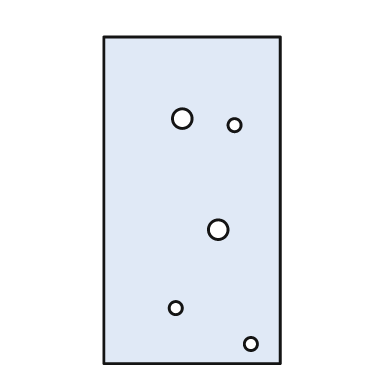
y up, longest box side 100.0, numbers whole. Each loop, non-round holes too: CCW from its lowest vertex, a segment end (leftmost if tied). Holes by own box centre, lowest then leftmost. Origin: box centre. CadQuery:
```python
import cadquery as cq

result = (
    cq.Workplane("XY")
    .moveTo(-27.0, -50.0)
    .lineTo(27.0, -50.0)
    .lineTo(27.0, 50.0)
    .lineTo(-27.0, 50.0)
    .close()
    .moveTo(18.0, -44.0)
    .circle(2.0)
    .moveTo(-5.0, -33.0)
    .circle(2.0)
    .moveTo(8.0, -9.0)
    .circle(3.0)
    .moveTo(13.0, 23.0)
    .circle(2.0)
    .moveTo(-3.0, 25.0)
    .circle(3.0)
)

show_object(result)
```